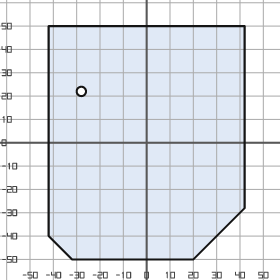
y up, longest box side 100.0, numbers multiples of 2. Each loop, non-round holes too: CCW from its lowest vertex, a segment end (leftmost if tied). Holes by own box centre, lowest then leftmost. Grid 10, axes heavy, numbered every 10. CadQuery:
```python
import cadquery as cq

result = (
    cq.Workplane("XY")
    .moveTo(-32.0, -50.0)
    .lineTo(20.0, -50.0)
    .lineTo(42.0, -28.0)
    .lineTo(42.0, 50.0)
    .lineTo(-42.0, 50.0)
    .lineTo(-42.0, -40.0)
    .close()
    .moveTo(-28.0, 22.0)
    .circle(2.0)
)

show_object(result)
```